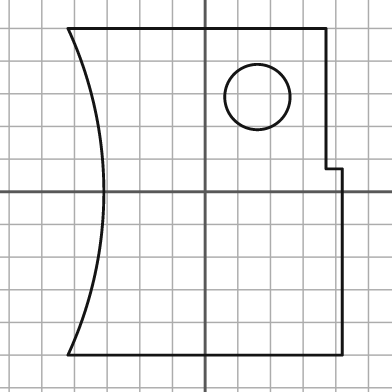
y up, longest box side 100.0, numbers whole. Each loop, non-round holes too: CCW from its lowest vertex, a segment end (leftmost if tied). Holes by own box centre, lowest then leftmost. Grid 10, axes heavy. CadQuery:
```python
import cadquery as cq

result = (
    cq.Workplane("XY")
    .moveTo(-42.0, -50.0)
    .lineTo(42.0, -50.0)
    .lineTo(42.0, 7.0)
    .lineTo(37.0, 7.0)
    .lineTo(37.0, 50.0)
    .lineTo(-42.0, 50.0)
    .threePointArc((-31.0, 0.0), (-42.0, -50.0))
    .close()
    .moveTo(16.0, 29.0)
    .circle(10.0)
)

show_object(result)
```